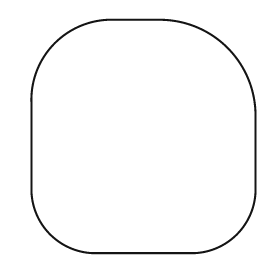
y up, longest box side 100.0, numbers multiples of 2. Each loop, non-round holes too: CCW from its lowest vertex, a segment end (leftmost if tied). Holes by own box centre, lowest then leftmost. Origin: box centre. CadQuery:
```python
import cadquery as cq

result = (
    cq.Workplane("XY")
    .moveTo(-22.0, -50.0)
    .lineTo(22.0, -50.0)
    .threePointArc((40.0, -42.0), (48.0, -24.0))
    .lineTo(48.0, 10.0)
    .threePointArc((36.0, 38.0), (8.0, 50.0))
    .lineTo(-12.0, 50.0)
    .threePointArc((-38.0, 40.0), (-48.0, 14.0))
    .lineTo(-48.0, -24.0)
    .threePointArc((-40.0, -42.0), (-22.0, -50.0))
    .close()
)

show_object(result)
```